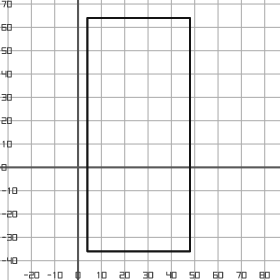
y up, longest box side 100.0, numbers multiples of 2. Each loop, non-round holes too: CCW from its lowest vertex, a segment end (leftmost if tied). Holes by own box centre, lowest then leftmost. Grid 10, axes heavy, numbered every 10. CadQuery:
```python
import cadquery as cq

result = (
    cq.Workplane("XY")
    .moveTo(4.0, -36.0)
    .lineTo(48.0, -36.0)
    .lineTo(48.0, 64.0)
    .lineTo(4.0, 64.0)
    .close()
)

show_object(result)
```